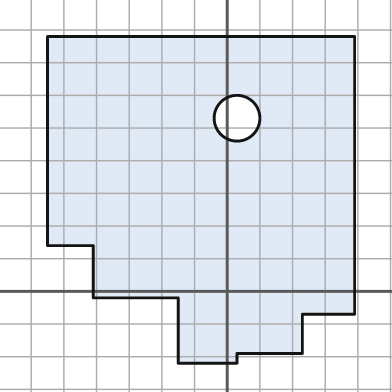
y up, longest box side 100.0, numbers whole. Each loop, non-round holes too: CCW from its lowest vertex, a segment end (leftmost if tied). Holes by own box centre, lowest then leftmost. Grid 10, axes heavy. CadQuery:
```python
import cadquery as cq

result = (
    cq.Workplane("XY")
    .moveTo(-15.0, -22.0)
    .lineTo(3.0, -22.0)
    .lineTo(3.0, -19.0)
    .lineTo(23.0, -19.0)
    .lineTo(23.0, -7.0)
    .lineTo(39.0, -7.0)
    .lineTo(39.0, 78.0)
    .lineTo(-55.0, 78.0)
    .lineTo(-55.0, 14.0)
    .lineTo(-41.0, 14.0)
    .lineTo(-41.0, -2.0)
    .lineTo(-15.0, -2.0)
    .close()
    .moveTo(3.0, 53.0)
    .circle(7.0)
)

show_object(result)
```